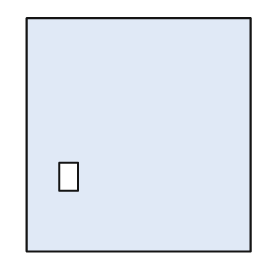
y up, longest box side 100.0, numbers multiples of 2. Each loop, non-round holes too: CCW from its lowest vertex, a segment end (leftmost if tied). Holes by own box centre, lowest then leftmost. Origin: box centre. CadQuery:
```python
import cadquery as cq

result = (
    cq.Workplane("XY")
    .moveTo(-48.0, -50.0)
    .lineTo(48.0, -50.0)
    .lineTo(48.0, 50.0)
    .lineTo(-48.0, 50.0)
    .close()
    .moveTo(-34.0, -24.0)
    .lineTo(-26.0, -24.0)
    .lineTo(-26.0, -12.0)
    .lineTo(-34.0, -12.0)
    .close()
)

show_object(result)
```